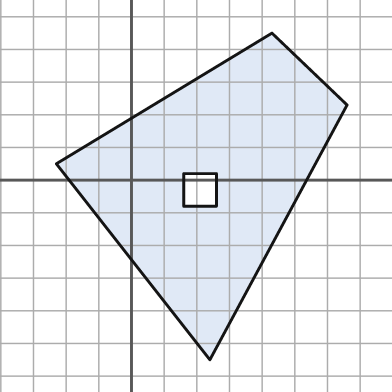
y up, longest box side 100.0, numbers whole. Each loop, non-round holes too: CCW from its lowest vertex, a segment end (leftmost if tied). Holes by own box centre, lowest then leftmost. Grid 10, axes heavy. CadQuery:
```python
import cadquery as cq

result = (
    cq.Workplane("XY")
    .moveTo(24.0, -55.0)
    .lineTo(66.0, 23.0)
    .lineTo(43.0, 45.0)
    .lineTo(-23.0, 5.0)
    .close()
    .moveTo(16.0, -8.0)
    .lineTo(26.0, -8.0)
    .lineTo(26.0, 2.0)
    .lineTo(16.0, 2.0)
    .close()
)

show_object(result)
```